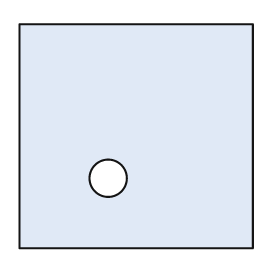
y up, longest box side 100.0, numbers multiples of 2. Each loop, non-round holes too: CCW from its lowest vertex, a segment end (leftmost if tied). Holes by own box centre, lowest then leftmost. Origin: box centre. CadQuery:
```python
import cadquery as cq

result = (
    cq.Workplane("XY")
    .moveTo(-50.0, -48.0)
    .lineTo(50.0, -48.0)
    .lineTo(50.0, 48.0)
    .lineTo(-50.0, 48.0)
    .close()
    .moveTo(-12.0, -18.0)
    .circle(8.0)
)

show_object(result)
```